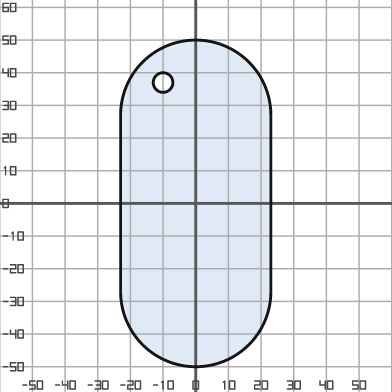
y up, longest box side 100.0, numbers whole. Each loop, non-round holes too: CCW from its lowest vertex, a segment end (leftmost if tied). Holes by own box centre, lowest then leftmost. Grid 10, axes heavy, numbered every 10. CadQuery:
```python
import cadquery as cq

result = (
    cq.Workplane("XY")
    .moveTo(-23.0, -27.0)
    .threePointArc((0.0, -50.0), (23.0, -27.0))
    .lineTo(23.0, 27.0)
    .threePointArc((0.0, 50.0), (-23.0, 27.0))
    .close()
    .moveTo(-10.0, 37.0)
    .circle(3.0)
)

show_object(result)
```